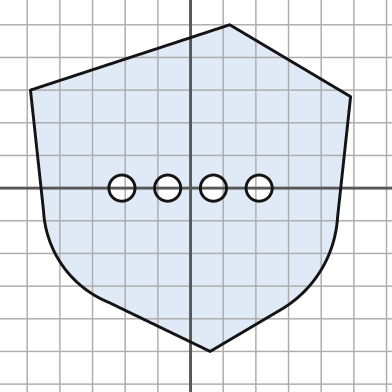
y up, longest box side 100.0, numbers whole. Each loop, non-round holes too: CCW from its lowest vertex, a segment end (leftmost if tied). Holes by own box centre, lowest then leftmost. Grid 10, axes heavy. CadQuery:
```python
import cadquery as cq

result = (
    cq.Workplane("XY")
    .moveTo(6.0, -50.0)
    .lineTo(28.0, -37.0)
    .threePointArc((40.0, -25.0), (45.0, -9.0))
    .lineTo(49.0, 28.0)
    .lineTo(12.0, 50.0)
    .lineTo(-49.0, 30.0)
    .lineTo(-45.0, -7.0)
    .threePointArc((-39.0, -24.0), (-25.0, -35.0))
    .close()
    .moveTo(-21.0, 0.0)
    .circle(4.0)
    .moveTo(-7.0, 0.0)
    .circle(4.0)
    .moveTo(7.0, 0.0)
    .circle(4.0)
    .moveTo(21.0, 0.0)
    .circle(4.0)
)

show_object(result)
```